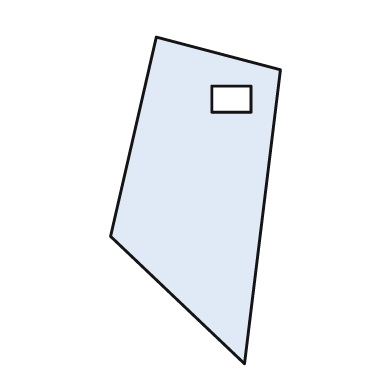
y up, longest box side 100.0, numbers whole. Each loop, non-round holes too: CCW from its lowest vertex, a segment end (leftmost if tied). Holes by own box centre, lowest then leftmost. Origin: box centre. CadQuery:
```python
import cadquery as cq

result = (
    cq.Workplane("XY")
    .moveTo(15.0, -50.0)
    .lineTo(26.0, 40.0)
    .lineTo(-12.0, 50.0)
    .lineTo(-26.0, -11.0)
    .close()
    .moveTo(5.0, 27.0)
    .lineTo(17.0, 27.0)
    .lineTo(17.0, 35.0)
    .lineTo(5.0, 35.0)
    .close()
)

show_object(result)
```